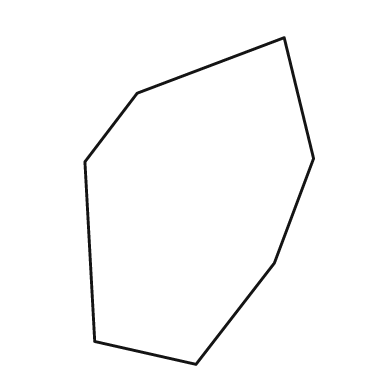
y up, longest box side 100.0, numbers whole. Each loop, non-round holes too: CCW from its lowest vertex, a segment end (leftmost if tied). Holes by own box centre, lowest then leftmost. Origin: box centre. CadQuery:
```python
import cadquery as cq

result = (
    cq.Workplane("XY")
    .moveTo(-1.0, -50.0)
    .lineTo(23.0, -19.0)
    .lineTo(35.0, 13.0)
    .lineTo(26.0, 50.0)
    .lineTo(-19.0, 33.0)
    .lineTo(-35.0, 12.0)
    .lineTo(-32.0, -43.0)
    .close()
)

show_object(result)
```